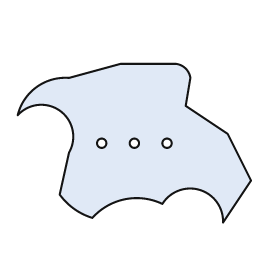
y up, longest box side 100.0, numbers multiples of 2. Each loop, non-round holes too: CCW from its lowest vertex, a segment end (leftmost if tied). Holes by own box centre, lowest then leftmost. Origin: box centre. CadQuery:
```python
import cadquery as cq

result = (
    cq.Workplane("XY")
    .moveTo(38.0, -34.0)
    .lineTo(50.0, -16.0)
    .lineTo(40.0, 4.0)
    .lineTo(22.0, 16.0)
    .lineTo(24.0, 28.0)
    .threePointArc((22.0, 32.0), (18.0, 34.0))
    .lineTo(-6.0, 34.0)
    .lineTo(-28.0, 28.0)
    .threePointArc((-42.0, 24.0), (-50.0, 12.0))
    .threePointArc((-32.0, 14.0), (-28.0, -4.0))
    .lineTo(-32.0, -22.0)
    .threePointArc((-26.0, -28.0), (-18.0, -32.0))
    .threePointArc((-4.0, -24.0), (12.0, -26.0))
    .threePointArc((28.0, -20.0), (38.0, -34.0))
    .close()
    .moveTo(-14.0, 0.0)
    .circle(2.0)
    .moveTo(0.0, 0.0)
    .circle(2.0)
    .moveTo(14.0, 0.0)
    .circle(2.0)
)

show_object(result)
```